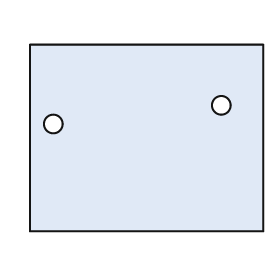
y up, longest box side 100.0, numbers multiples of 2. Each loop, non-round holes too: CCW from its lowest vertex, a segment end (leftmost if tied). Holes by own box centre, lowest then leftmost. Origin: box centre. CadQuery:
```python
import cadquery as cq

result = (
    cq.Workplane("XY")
    .moveTo(-50.0, -40.0)
    .lineTo(50.0, -40.0)
    .lineTo(50.0, 40.0)
    .lineTo(-50.0, 40.0)
    .close()
    .moveTo(-40.0, 6.0)
    .circle(4.0)
    .moveTo(32.0, 14.0)
    .circle(4.0)
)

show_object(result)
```